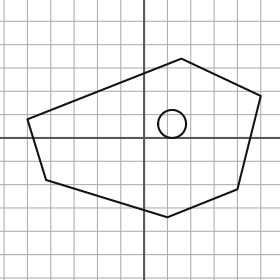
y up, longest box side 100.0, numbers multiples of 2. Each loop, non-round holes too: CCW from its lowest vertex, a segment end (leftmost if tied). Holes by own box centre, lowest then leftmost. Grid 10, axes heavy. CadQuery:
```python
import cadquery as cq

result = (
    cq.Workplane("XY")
    .moveTo(10.0, -34.0)
    .lineTo(40.0, -22.0)
    .lineTo(50.0, 18.0)
    .lineTo(16.0, 34.0)
    .lineTo(-50.0, 8.0)
    .lineTo(-42.0, -18.0)
    .close()
    .moveTo(12.0, 6.0)
    .circle(6.0)
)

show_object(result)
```